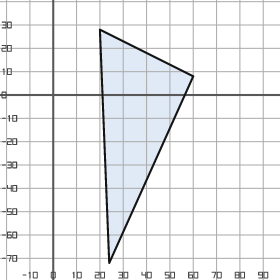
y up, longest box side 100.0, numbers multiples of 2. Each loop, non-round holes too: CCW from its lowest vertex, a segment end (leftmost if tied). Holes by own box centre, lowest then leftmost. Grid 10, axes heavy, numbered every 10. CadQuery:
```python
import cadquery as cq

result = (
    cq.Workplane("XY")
    .moveTo(24.0, -72.0)
    .lineTo(60.0, 8.0)
    .lineTo(20.0, 28.0)
    .close()
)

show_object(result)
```